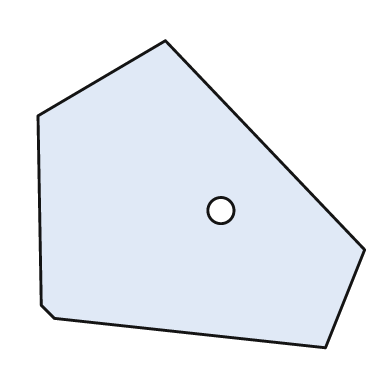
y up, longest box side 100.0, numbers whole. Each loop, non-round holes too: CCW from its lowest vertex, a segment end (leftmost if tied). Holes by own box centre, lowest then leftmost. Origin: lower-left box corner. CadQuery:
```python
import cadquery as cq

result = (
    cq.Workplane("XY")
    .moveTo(88.0, 0.0)
    .lineTo(100.0, 30.0)
    .lineTo(39.0, 94.0)
    .lineTo(0.0, 71.0)
    .lineTo(1.0, 13.0)
    .lineTo(5.0, 9.0)
    .close()
    .moveTo(56.0, 42.0)
    .circle(4.0)
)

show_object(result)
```